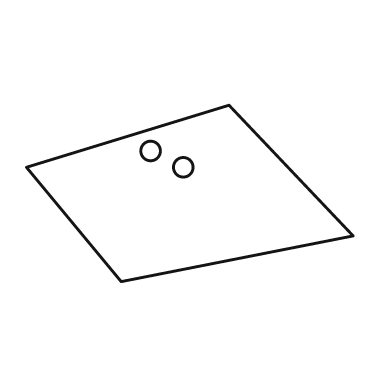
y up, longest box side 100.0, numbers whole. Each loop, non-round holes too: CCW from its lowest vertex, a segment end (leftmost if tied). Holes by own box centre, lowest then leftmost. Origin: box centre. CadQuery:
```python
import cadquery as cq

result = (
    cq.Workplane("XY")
    .moveTo(-21.0, -27.0)
    .lineTo(50.0, -13.0)
    .lineTo(12.0, 27.0)
    .lineTo(-50.0, 8.0)
    .close()
    .moveTo(-2.0, 8.0)
    .circle(3.0)
    .moveTo(-12.0, 13.0)
    .circle(3.0)
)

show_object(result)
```